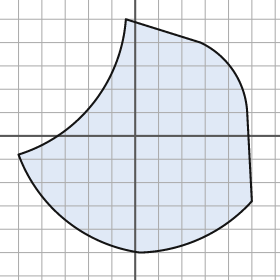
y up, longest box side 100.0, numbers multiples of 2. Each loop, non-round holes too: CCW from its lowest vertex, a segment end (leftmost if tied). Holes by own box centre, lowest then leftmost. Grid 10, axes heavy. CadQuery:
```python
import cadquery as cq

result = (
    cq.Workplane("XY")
    .moveTo(2.0, -50.0)
    .threePointArc((28.0, -44.0), (50.0, -28.0))
    .lineTo(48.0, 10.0)
    .threePointArc((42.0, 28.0), (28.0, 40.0))
    .lineTo(-4.0, 50.0)
    .threePointArc((-18.0, 14.0), (-50.0, -8.0))
    .threePointArc((-30.0, -36.0), (2.0, -50.0))
    .close()
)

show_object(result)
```